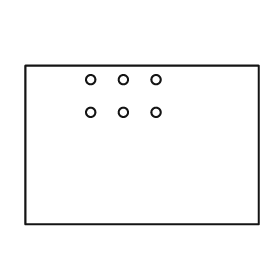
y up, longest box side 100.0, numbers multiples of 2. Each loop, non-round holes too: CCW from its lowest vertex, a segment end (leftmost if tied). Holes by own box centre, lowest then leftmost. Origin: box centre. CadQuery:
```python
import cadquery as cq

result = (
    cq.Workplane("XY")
    .moveTo(-50.0, -34.0)
    .lineTo(50.0, -34.0)
    .lineTo(50.0, 34.0)
    .lineTo(-50.0, 34.0)
    .close()
    .moveTo(-22.0, 14.0)
    .circle(2.0)
    .moveTo(-8.0, 14.0)
    .circle(2.0)
    .moveTo(6.0, 14.0)
    .circle(2.0)
    .moveTo(-22.0, 28.0)
    .circle(2.0)
    .moveTo(-8.0, 28.0)
    .circle(2.0)
    .moveTo(6.0, 28.0)
    .circle(2.0)
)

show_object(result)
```